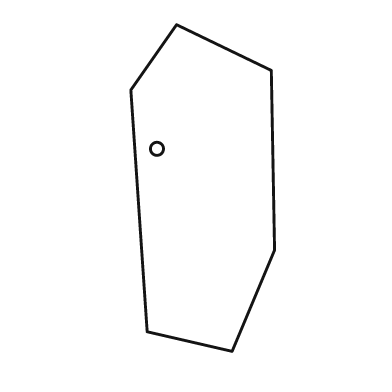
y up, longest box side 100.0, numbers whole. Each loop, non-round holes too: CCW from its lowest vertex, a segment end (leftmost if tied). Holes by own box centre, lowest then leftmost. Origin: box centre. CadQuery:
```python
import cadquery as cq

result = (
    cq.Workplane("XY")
    .moveTo(9.0, -50.0)
    .lineTo(22.0, -19.0)
    .lineTo(21.0, 36.0)
    .lineTo(-8.0, 50.0)
    .lineTo(-22.0, 30.0)
    .lineTo(-17.0, -44.0)
    .close()
    .moveTo(-14.0, 12.0)
    .circle(2.0)
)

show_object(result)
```